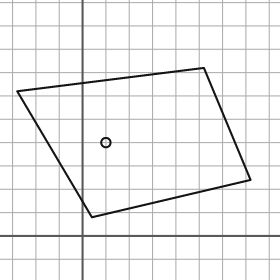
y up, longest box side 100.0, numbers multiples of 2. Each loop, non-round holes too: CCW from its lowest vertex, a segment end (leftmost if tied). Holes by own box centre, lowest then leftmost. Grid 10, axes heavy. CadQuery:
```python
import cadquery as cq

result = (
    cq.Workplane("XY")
    .moveTo(4.0, 8.0)
    .lineTo(72.0, 24.0)
    .lineTo(52.0, 72.0)
    .lineTo(-28.0, 62.0)
    .close()
    .moveTo(10.0, 40.0)
    .circle(2.0)
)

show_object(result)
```